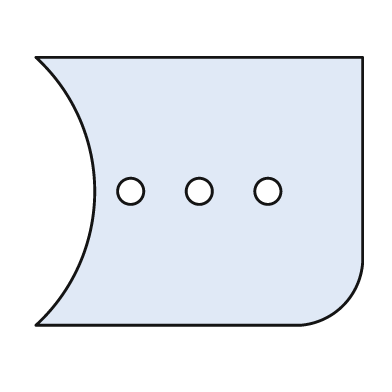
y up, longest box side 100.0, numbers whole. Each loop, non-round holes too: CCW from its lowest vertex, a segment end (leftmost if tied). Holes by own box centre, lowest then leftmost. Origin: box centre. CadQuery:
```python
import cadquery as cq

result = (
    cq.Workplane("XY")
    .moveTo(-50.0, -41.0)
    .lineTo(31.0, -41.0)
    .threePointArc((44.0, -35.0), (50.0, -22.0))
    .lineTo(50.0, 41.0)
    .lineTo(-50.0, 41.0)
    .threePointArc((-32.0, 0.0), (-50.0, -41.0))
    .close()
    .moveTo(-21.0, 0.0)
    .circle(4.0)
    .moveTo(0.0, 0.0)
    .circle(4.0)
    .moveTo(21.0, 0.0)
    .circle(4.0)
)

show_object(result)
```